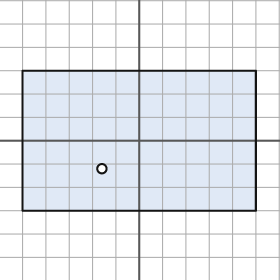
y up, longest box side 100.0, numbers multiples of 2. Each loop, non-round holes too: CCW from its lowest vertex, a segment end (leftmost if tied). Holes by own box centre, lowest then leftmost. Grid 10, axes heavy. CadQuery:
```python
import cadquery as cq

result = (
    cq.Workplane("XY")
    .moveTo(-50.0, -30.0)
    .lineTo(50.0, -30.0)
    .lineTo(50.0, 30.0)
    .lineTo(-50.0, 30.0)
    .close()
    .moveTo(-16.0, -12.0)
    .circle(2.0)
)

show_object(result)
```